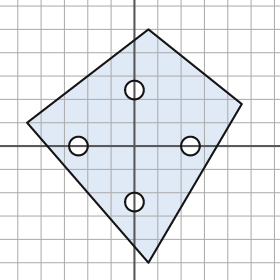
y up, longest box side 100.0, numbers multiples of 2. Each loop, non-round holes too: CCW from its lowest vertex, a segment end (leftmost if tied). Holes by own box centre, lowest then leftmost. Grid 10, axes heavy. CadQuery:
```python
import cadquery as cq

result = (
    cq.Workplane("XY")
    .moveTo(6.0, -50.0)
    .lineTo(46.0, 18.0)
    .lineTo(6.0, 50.0)
    .lineTo(-46.0, 10.0)
    .close()
    .moveTo(0.0, -24.0)
    .circle(4.0)
    .moveTo(-24.0, 0.0)
    .circle(4.0)
    .moveTo(24.0, 0.0)
    .circle(4.0)
    .moveTo(0.0, 24.0)
    .circle(4.0)
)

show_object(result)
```